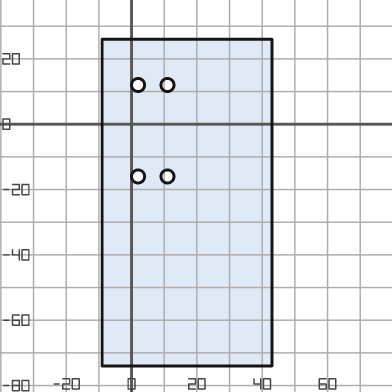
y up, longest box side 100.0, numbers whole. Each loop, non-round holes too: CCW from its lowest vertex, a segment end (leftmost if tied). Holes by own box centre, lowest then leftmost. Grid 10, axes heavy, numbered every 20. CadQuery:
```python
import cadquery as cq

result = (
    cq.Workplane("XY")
    .moveTo(-9.0, -74.0)
    .lineTo(43.0, -74.0)
    .lineTo(43.0, 26.0)
    .lineTo(-9.0, 26.0)
    .close()
    .moveTo(2.0, -16.0)
    .circle(2.0)
    .moveTo(11.0, -16.0)
    .circle(2.0)
    .moveTo(2.0, 12.0)
    .circle(2.0)
    .moveTo(11.0, 12.0)
    .circle(2.0)
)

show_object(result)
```